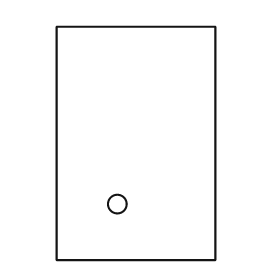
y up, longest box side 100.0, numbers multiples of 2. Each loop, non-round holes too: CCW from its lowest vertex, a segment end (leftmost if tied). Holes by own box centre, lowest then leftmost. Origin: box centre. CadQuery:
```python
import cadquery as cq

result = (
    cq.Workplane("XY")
    .moveTo(-34.0, -50.0)
    .lineTo(34.0, -50.0)
    .lineTo(34.0, 50.0)
    .lineTo(-34.0, 50.0)
    .close()
    .moveTo(-8.0, -26.0)
    .circle(4.0)
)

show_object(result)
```